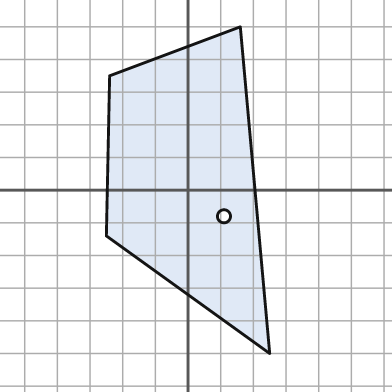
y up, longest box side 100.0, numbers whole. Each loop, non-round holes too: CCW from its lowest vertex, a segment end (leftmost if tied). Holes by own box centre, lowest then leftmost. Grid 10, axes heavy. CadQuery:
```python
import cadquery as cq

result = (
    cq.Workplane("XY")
    .moveTo(25.0, -50.0)
    .lineTo(16.0, 50.0)
    .lineTo(-24.0, 35.0)
    .lineTo(-25.0, -14.0)
    .close()
    .moveTo(11.0, -8.0)
    .circle(2.0)
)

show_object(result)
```